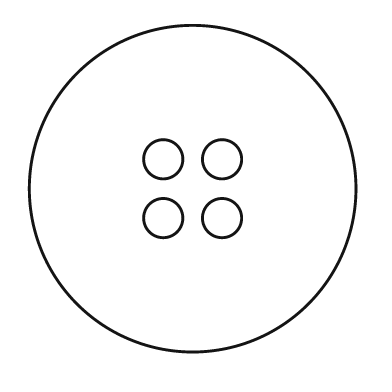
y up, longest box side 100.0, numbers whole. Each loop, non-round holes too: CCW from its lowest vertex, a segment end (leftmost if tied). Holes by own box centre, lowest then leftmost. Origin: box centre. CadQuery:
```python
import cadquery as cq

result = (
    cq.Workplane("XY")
    .moveTo(0.0, 0.0)
    .circle(50.0)
    .moveTo(-9.0, -9.0)
    .circle(6.0)
    .moveTo(9.0, -9.0)
    .circle(6.0)
    .moveTo(-9.0, 9.0)
    .circle(6.0)
    .moveTo(9.0, 9.0)
    .circle(6.0)
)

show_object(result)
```